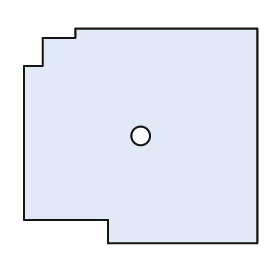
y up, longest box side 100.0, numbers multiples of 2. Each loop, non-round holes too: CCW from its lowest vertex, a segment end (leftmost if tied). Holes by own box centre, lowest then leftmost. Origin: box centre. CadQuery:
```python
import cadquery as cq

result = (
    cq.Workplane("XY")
    .moveTo(-14.0, -46.0)
    .lineTo(50.0, -46.0)
    .lineTo(50.0, 46.0)
    .lineTo(-28.0, 46.0)
    .lineTo(-28.0, 42.0)
    .lineTo(-42.0, 42.0)
    .lineTo(-42.0, 30.0)
    .lineTo(-50.0, 30.0)
    .lineTo(-50.0, -36.0)
    .lineTo(-14.0, -36.0)
    .close()
    .moveTo(0.0, 0.0)
    .circle(4.0)
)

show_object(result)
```